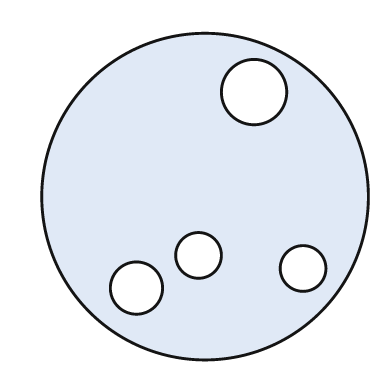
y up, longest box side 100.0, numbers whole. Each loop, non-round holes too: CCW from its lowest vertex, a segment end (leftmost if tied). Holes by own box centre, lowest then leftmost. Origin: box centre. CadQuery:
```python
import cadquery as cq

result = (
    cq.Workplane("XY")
    .moveTo(0.0, 0.0)
    .circle(50.0)
    .moveTo(-21.0, -28.0)
    .circle(8.0)
    .moveTo(30.0, -22.0)
    .circle(7.0)
    .moveTo(-2.0, -18.0)
    .circle(7.0)
    .moveTo(15.0, 32.0)
    .circle(10.0)
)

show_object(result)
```